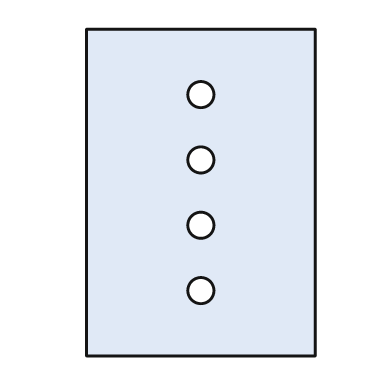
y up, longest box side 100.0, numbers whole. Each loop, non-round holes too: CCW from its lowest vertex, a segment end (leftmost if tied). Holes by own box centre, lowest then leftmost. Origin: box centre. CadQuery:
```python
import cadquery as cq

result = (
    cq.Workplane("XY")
    .moveTo(-35.0, -50.0)
    .lineTo(35.0, -50.0)
    .lineTo(35.0, 50.0)
    .lineTo(-35.0, 50.0)
    .close()
    .moveTo(0.0, -30.0)
    .circle(4.0)
    .moveTo(0.0, -10.0)
    .circle(4.0)
    .moveTo(0.0, 10.0)
    .circle(4.0)
    .moveTo(0.0, 30.0)
    .circle(4.0)
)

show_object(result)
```